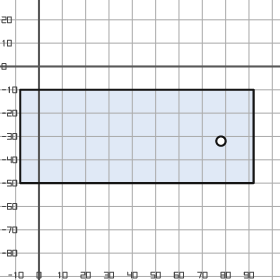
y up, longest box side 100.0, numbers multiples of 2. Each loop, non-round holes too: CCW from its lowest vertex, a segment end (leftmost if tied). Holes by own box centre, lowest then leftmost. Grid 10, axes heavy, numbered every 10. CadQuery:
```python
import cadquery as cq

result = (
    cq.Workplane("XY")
    .moveTo(-8.0, -50.0)
    .lineTo(92.0, -50.0)
    .lineTo(92.0, -10.0)
    .lineTo(-8.0, -10.0)
    .close()
    .moveTo(78.0, -32.0)
    .circle(2.0)
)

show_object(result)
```